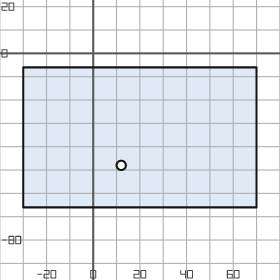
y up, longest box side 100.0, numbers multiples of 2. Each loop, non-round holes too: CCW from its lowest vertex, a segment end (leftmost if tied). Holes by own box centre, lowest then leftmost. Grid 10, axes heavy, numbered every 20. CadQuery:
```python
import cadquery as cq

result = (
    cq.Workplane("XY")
    .moveTo(-30.0, -66.0)
    .lineTo(70.0, -66.0)
    .lineTo(70.0, -6.0)
    .lineTo(-30.0, -6.0)
    .close()
    .moveTo(12.0, -48.0)
    .circle(2.0)
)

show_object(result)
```